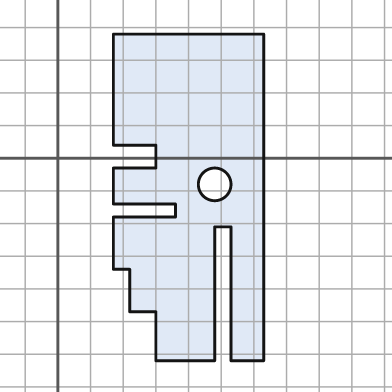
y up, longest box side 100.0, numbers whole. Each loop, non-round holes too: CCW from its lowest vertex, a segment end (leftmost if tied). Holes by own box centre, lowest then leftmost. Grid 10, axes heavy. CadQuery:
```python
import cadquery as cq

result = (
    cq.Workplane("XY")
    .moveTo(30.0, -62.0)
    .lineTo(48.0, -62.0)
    .lineTo(48.0, -21.0)
    .lineTo(53.0, -21.0)
    .lineTo(53.0, -62.0)
    .lineTo(63.0, -62.0)
    .lineTo(63.0, 38.0)
    .lineTo(17.0, 38.0)
    .lineTo(17.0, 4.0)
    .lineTo(30.0, 4.0)
    .lineTo(30.0, -3.0)
    .lineTo(17.0, -3.0)
    .lineTo(17.0, -14.0)
    .lineTo(36.0, -14.0)
    .lineTo(36.0, -18.0)
    .lineTo(17.0, -18.0)
    .lineTo(17.0, -34.0)
    .lineTo(22.0, -34.0)
    .lineTo(22.0, -47.0)
    .lineTo(30.0, -47.0)
    .close()
    .moveTo(48.0, -8.0)
    .circle(5.0)
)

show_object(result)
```